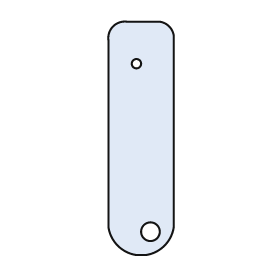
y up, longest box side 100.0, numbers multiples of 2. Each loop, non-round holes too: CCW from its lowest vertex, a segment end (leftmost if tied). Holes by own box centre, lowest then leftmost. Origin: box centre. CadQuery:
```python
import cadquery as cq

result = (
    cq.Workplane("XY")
    .moveTo(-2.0, -50.0)
    .lineTo(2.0, -50.0)
    .threePointArc((10.0, -46.0), (14.0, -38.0))
    .lineTo(14.0, 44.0)
    .threePointArc((12.0, 48.0), (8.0, 50.0))
    .lineTo(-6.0, 50.0)
    .threePointArc((-12.0, 48.0), (-14.0, 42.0))
    .lineTo(-14.0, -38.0)
    .threePointArc((-10.0, -46.0), (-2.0, -50.0))
    .close()
    .moveTo(4.0, -40.0)
    .circle(4.0)
    .moveTo(-2.0, 32.0)
    .circle(2.0)
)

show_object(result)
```